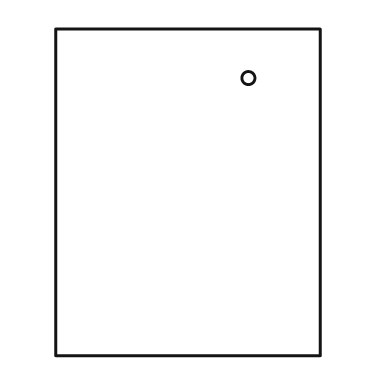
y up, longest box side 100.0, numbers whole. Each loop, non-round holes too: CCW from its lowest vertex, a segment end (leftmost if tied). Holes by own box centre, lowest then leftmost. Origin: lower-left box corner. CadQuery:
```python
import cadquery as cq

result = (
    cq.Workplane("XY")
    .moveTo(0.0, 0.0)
    .lineTo(81.0, 0.0)
    .lineTo(81.0, 100.0)
    .lineTo(0.0, 100.0)
    .close()
    .moveTo(59.0, 85.0)
    .circle(2.0)
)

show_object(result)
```